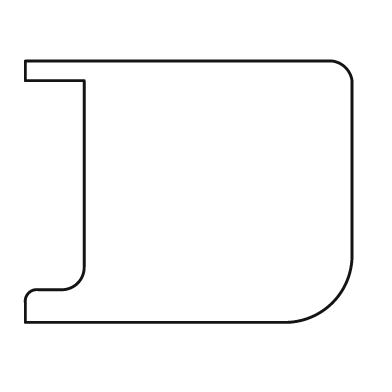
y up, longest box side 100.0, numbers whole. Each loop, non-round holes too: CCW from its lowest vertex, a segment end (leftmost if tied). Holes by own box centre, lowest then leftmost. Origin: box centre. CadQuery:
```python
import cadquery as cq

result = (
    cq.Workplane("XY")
    .moveTo(-50.0, -40.0)
    .lineTo(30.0, -40.0)
    .threePointArc((44.0, -34.0), (50.0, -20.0))
    .lineTo(50.0, 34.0)
    .threePointArc((48.0, 38.0), (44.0, 40.0))
    .lineTo(-50.0, 40.0)
    .lineTo(-50.0, 34.0)
    .lineTo(-32.0, 34.0)
    .lineTo(-32.0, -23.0)
    .threePointArc((-34.0, -28.0), (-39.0, -30.0))
    .lineTo(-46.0, -30.0)
    .threePointArc((-49.0, -31.0), (-50.0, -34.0))
    .close()
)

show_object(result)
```